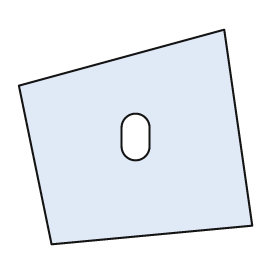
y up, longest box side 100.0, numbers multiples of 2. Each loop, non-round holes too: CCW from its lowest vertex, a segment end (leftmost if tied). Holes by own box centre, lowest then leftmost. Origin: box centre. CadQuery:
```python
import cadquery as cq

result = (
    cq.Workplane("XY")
    .moveTo(-36.0, -46.0)
    .lineTo(50.0, -38.0)
    .lineTo(38.0, 46.0)
    .lineTo(-50.0, 22.0)
    .close()
    .moveTo(-6.0, -4.0)
    .threePointArc((0.0, -10.0), (6.0, -4.0))
    .lineTo(6.0, 4.0)
    .threePointArc((0.0, 10.0), (-6.0, 4.0))
    .close()
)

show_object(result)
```